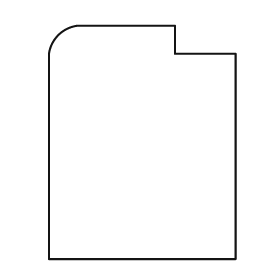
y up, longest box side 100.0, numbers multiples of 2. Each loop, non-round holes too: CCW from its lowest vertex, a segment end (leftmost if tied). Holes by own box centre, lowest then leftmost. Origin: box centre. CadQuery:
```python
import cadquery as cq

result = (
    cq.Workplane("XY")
    .moveTo(-40.0, -50.0)
    .lineTo(40.0, -50.0)
    .lineTo(40.0, 38.0)
    .lineTo(14.0, 38.0)
    .lineTo(14.0, 50.0)
    .lineTo(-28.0, 50.0)
    .threePointArc((-36.0, 46.0), (-40.0, 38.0))
    .close()
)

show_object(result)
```